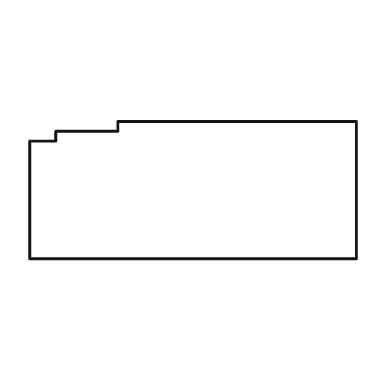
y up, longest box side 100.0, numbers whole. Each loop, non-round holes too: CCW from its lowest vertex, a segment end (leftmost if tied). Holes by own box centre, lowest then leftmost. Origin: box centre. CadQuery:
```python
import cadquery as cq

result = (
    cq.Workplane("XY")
    .moveTo(-50.0, -21.0)
    .lineTo(50.0, -21.0)
    .lineTo(50.0, 21.0)
    .lineTo(-23.0, 21.0)
    .lineTo(-23.0, 18.0)
    .lineTo(-42.0, 18.0)
    .lineTo(-42.0, 15.0)
    .lineTo(-50.0, 15.0)
    .close()
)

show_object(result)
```